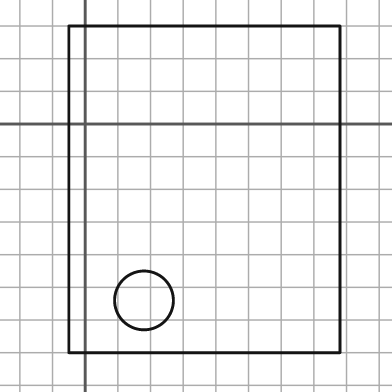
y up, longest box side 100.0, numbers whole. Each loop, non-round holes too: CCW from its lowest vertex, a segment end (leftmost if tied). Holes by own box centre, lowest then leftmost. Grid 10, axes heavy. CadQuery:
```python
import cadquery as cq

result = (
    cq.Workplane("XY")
    .moveTo(-5.0, -70.0)
    .lineTo(78.0, -70.0)
    .lineTo(78.0, 30.0)
    .lineTo(-5.0, 30.0)
    .close()
    .moveTo(18.0, -54.0)
    .circle(9.0)
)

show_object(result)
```